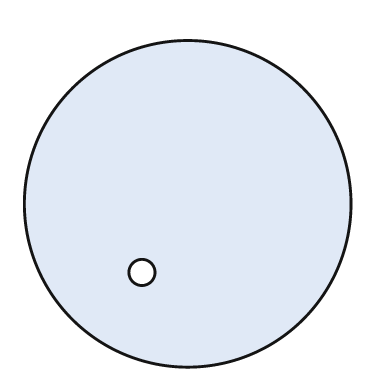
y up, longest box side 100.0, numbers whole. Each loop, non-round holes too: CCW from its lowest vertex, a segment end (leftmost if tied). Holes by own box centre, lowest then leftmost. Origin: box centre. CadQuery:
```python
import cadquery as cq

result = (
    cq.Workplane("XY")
    .moveTo(0.0, 0.0)
    .circle(50.0)
    .moveTo(-14.0, -21.0)
    .circle(4.0)
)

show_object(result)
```